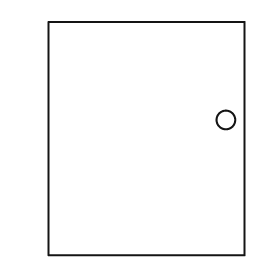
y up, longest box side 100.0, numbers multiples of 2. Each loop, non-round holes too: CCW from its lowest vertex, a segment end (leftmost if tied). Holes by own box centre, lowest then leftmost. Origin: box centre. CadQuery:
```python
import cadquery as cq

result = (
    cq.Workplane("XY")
    .moveTo(-42.0, -50.0)
    .lineTo(42.0, -50.0)
    .lineTo(42.0, 50.0)
    .lineTo(-42.0, 50.0)
    .close()
    .moveTo(34.0, 8.0)
    .circle(4.0)
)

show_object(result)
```